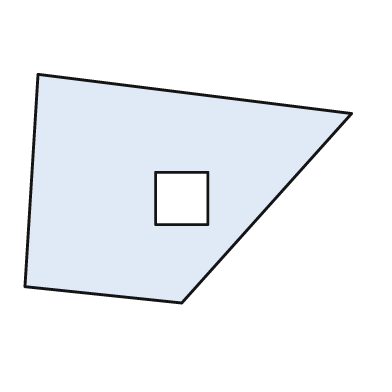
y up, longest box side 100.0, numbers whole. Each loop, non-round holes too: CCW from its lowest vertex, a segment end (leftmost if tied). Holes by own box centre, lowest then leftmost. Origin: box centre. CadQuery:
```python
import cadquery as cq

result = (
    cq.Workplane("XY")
    .moveTo(-2.0, -35.0)
    .lineTo(50.0, 23.0)
    .lineTo(-46.0, 35.0)
    .lineTo(-50.0, -30.0)
    .close()
    .moveTo(-10.0, -11.0)
    .lineTo(6.0, -11.0)
    .lineTo(6.0, 5.0)
    .lineTo(-10.0, 5.0)
    .close()
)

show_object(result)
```